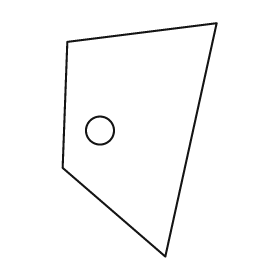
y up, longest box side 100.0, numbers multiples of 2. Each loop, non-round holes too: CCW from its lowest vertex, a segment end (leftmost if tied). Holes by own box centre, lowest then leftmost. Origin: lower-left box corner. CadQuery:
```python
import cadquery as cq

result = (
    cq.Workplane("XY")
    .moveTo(44.0, 0.0)
    .lineTo(66.0, 100.0)
    .lineTo(2.0, 92.0)
    .lineTo(0.0, 38.0)
    .close()
    .moveTo(16.0, 54.0)
    .circle(6.0)
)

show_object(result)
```